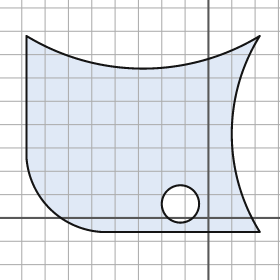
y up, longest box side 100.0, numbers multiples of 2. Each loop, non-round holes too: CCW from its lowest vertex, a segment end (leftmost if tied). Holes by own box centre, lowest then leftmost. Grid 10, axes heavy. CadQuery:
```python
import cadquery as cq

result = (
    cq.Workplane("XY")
    .moveTo(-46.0, -6.0)
    .lineTo(22.0, -6.0)
    .threePointArc((10.0, 36.0), (22.0, 78.0))
    .threePointArc((-28.0, 64.0), (-78.0, 78.0))
    .lineTo(-78.0, 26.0)
    .threePointArc((-68.0, 4.0), (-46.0, -6.0))
    .close()
    .moveTo(-12.0, 6.0)
    .circle(8.0)
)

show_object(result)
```